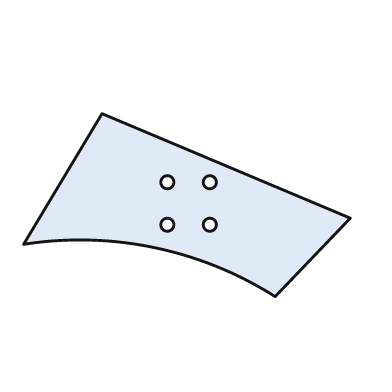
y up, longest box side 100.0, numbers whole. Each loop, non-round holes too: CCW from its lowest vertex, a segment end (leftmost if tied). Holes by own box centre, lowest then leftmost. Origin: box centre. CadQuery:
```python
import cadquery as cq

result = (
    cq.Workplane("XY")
    .moveTo(27.0, -28.0)
    .lineTo(50.0, -4.0)
    .lineTo(-26.0, 28.0)
    .lineTo(-50.0, -12.0)
    .threePointArc((-10.0, -13.0), (27.0, -28.0))
    .close()
    .moveTo(-6.0, -6.0)
    .circle(2.0)
    .moveTo(7.0, -6.0)
    .circle(2.0)
    .moveTo(-6.0, 7.0)
    .circle(2.0)
    .moveTo(7.0, 7.0)
    .circle(2.0)
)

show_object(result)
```